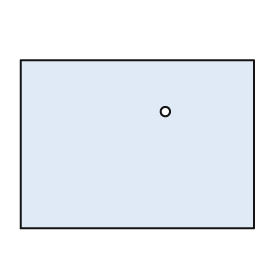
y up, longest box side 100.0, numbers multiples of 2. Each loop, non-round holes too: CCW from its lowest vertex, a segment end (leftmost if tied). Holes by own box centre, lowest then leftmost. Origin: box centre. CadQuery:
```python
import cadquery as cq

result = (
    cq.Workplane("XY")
    .moveTo(-50.0, -36.0)
    .lineTo(50.0, -36.0)
    .lineTo(50.0, 36.0)
    .lineTo(-50.0, 36.0)
    .close()
    .moveTo(12.0, 14.0)
    .circle(2.0)
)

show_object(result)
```